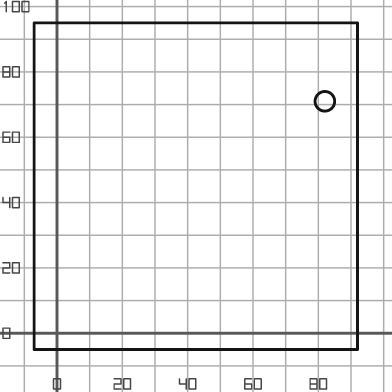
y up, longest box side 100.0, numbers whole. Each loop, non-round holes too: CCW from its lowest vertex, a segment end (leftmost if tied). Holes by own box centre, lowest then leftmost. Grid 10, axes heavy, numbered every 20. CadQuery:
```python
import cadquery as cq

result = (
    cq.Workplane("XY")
    .moveTo(-7.0, -5.0)
    .lineTo(92.0, -5.0)
    .lineTo(92.0, 95.0)
    .lineTo(-7.0, 95.0)
    .close()
    .moveTo(82.0, 71.0)
    .circle(3.0)
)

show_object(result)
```